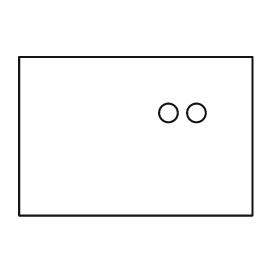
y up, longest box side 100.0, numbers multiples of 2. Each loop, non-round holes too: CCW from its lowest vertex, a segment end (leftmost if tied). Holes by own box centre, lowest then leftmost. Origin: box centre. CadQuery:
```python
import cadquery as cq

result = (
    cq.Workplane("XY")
    .moveTo(-50.0, -34.0)
    .lineTo(50.0, -34.0)
    .lineTo(50.0, 34.0)
    .lineTo(-50.0, 34.0)
    .close()
    .moveTo(14.0, 10.0)
    .circle(4.0)
    .moveTo(26.0, 10.0)
    .circle(4.0)
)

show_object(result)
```